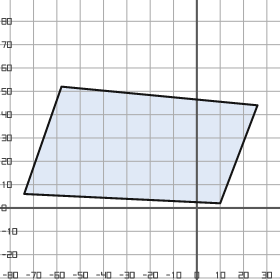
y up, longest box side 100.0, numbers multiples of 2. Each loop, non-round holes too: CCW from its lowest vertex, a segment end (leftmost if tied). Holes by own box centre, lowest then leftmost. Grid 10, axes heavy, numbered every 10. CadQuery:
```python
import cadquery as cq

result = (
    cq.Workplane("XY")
    .moveTo(10.0, 2.0)
    .lineTo(26.0, 44.0)
    .lineTo(-58.0, 52.0)
    .lineTo(-74.0, 6.0)
    .close()
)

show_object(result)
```